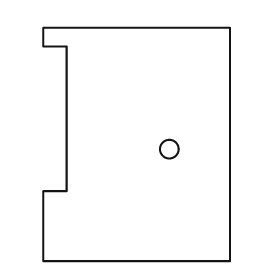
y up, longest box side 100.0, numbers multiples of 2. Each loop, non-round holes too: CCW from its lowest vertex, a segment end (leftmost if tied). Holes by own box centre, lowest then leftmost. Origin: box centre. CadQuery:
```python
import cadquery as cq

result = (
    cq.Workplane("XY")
    .moveTo(-40.0, -50.0)
    .lineTo(40.0, -50.0)
    .lineTo(40.0, 50.0)
    .lineTo(-40.0, 50.0)
    .lineTo(-40.0, 42.0)
    .lineTo(-30.0, 42.0)
    .lineTo(-30.0, -20.0)
    .lineTo(-40.0, -20.0)
    .close()
    .moveTo(14.0, -2.0)
    .circle(4.0)
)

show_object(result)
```